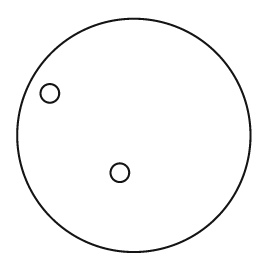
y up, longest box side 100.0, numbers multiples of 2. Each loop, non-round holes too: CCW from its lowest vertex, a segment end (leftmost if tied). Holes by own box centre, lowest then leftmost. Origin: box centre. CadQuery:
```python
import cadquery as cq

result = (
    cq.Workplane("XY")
    .moveTo(0.0, 0.0)
    .circle(50.0)
    .moveTo(-6.0, -16.0)
    .circle(4.0)
    .moveTo(-36.0, 18.0)
    .circle(4.0)
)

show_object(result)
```